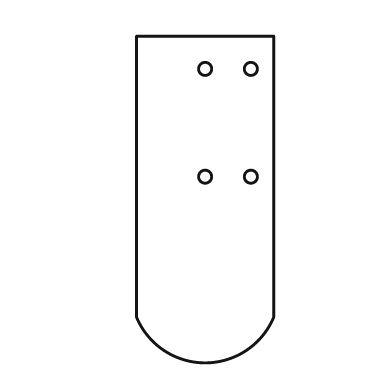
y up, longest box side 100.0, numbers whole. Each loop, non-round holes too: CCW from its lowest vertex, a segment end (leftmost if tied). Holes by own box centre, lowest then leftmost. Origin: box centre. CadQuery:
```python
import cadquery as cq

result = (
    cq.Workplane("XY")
    .moveTo(-21.0, -36.0)
    .threePointArc((0.0, -50.0), (21.0, -36.0))
    .lineTo(21.0, 50.0)
    .lineTo(-21.0, 50.0)
    .close()
    .moveTo(0.0, 7.0)
    .circle(2.0)
    .moveTo(14.0, 7.0)
    .circle(2.0)
    .moveTo(0.0, 40.0)
    .circle(2.0)
    .moveTo(14.0, 40.0)
    .circle(2.0)
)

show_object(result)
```